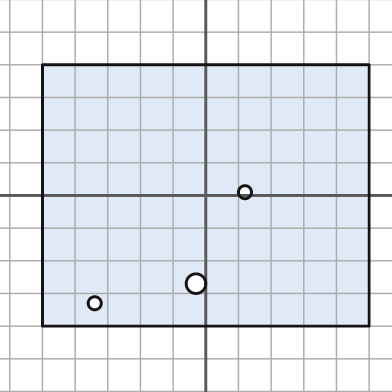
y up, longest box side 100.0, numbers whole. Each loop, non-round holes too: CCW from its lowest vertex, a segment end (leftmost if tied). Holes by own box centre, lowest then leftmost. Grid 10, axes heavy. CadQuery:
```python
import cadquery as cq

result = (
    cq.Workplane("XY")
    .moveTo(-50.0, -40.0)
    .lineTo(50.0, -40.0)
    .lineTo(50.0, 40.0)
    .lineTo(-50.0, 40.0)
    .close()
    .moveTo(-34.0, -33.0)
    .circle(2.0)
    .moveTo(-3.0, -27.0)
    .circle(3.0)
    .moveTo(12.0, 1.0)
    .circle(2.0)
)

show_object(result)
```